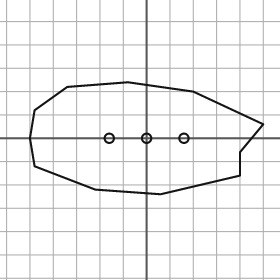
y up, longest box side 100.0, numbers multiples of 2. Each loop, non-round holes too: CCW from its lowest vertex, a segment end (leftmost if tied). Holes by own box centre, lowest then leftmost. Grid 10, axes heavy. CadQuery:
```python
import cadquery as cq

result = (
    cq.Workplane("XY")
    .moveTo(6.0, -24.0)
    .lineTo(40.0, -16.0)
    .lineTo(40.0, -6.0)
    .lineTo(50.0, 6.0)
    .lineTo(20.0, 20.0)
    .lineTo(-8.0, 24.0)
    .lineTo(-34.0, 22.0)
    .lineTo(-48.0, 12.0)
    .lineTo(-50.0, 0.0)
    .lineTo(-48.0, -12.0)
    .lineTo(-22.0, -22.0)
    .close()
    .moveTo(-16.0, 0.0)
    .circle(2.0)
    .moveTo(0.0, 0.0)
    .circle(2.0)
    .moveTo(16.0, 0.0)
    .circle(2.0)
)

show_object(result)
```